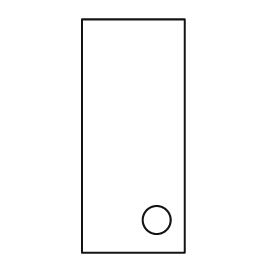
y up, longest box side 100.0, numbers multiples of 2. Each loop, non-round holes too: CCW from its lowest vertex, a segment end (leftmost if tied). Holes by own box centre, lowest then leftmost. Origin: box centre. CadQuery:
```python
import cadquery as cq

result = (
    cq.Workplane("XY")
    .moveTo(-22.0, -50.0)
    .lineTo(22.0, -50.0)
    .lineTo(22.0, 50.0)
    .lineTo(-22.0, 50.0)
    .close()
    .moveTo(10.0, -36.0)
    .circle(6.0)
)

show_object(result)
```